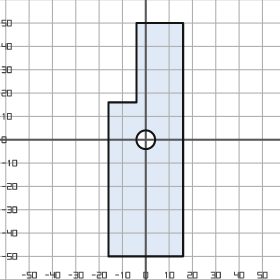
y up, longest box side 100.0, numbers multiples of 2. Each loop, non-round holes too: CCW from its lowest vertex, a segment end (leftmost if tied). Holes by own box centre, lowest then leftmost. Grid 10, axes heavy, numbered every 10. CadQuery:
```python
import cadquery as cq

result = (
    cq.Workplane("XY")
    .moveTo(-16.0, -50.0)
    .lineTo(16.0, -50.0)
    .lineTo(16.0, 50.0)
    .lineTo(-4.0, 50.0)
    .lineTo(-4.0, 16.0)
    .lineTo(-16.0, 16.0)
    .close()
    .moveTo(0.0, 0.0)
    .circle(4.0)
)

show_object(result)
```